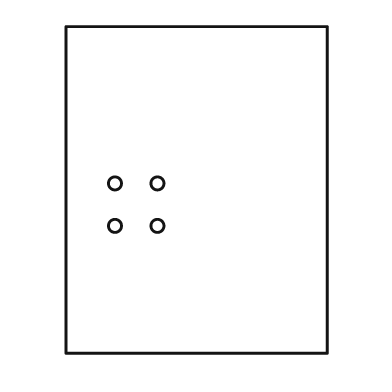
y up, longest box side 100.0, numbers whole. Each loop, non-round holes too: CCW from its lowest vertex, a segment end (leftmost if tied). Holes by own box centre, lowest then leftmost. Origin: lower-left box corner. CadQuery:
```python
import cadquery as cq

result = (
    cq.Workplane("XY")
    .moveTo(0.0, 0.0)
    .lineTo(80.0, 0.0)
    .lineTo(80.0, 100.0)
    .lineTo(0.0, 100.0)
    .close()
    .moveTo(15.0, 39.0)
    .circle(2.0)
    .moveTo(28.0, 39.0)
    .circle(2.0)
    .moveTo(15.0, 52.0)
    .circle(2.0)
    .moveTo(28.0, 52.0)
    .circle(2.0)
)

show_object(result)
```